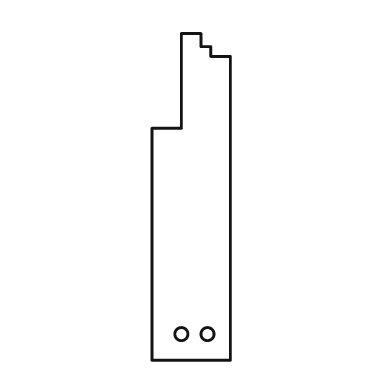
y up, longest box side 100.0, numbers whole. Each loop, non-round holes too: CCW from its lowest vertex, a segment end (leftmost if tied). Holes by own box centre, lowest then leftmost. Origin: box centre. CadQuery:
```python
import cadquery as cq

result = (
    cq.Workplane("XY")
    .moveTo(-12.0, -50.0)
    .lineTo(12.0, -50.0)
    .lineTo(12.0, 43.0)
    .lineTo(6.0, 43.0)
    .lineTo(6.0, 46.0)
    .lineTo(3.0, 46.0)
    .lineTo(3.0, 50.0)
    .lineTo(-3.0, 50.0)
    .lineTo(-3.0, 21.0)
    .lineTo(-12.0, 21.0)
    .close()
    .moveTo(-3.0, -42.0)
    .circle(2.0)
    .moveTo(5.0, -42.0)
    .circle(2.0)
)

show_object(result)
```